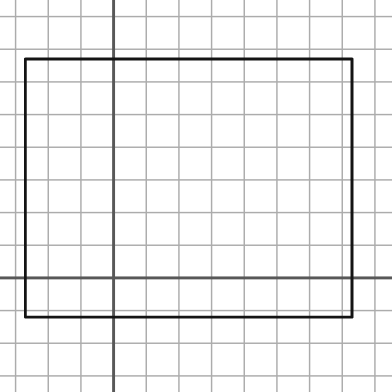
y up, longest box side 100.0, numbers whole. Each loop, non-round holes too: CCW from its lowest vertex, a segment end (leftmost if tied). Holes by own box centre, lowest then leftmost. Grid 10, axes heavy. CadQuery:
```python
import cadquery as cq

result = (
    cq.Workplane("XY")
    .moveTo(-27.0, -12.0)
    .lineTo(73.0, -12.0)
    .lineTo(73.0, 67.0)
    .lineTo(-27.0, 67.0)
    .close()
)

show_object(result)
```